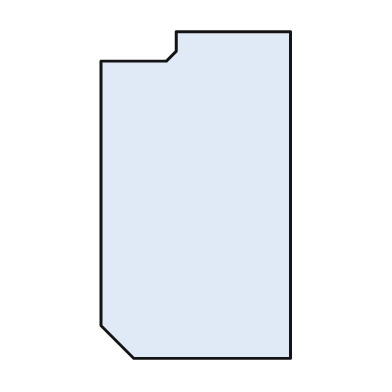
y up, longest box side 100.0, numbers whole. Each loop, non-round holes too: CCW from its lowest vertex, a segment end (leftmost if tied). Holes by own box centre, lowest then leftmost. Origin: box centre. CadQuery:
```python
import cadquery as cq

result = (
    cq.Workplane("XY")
    .moveTo(-19.0, -50.0)
    .lineTo(29.0, -50.0)
    .lineTo(29.0, 50.0)
    .lineTo(-6.0, 50.0)
    .lineTo(-6.0, 44.0)
    .lineTo(-9.0, 41.0)
    .lineTo(-29.0, 41.0)
    .lineTo(-29.0, -40.0)
    .close()
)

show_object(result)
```